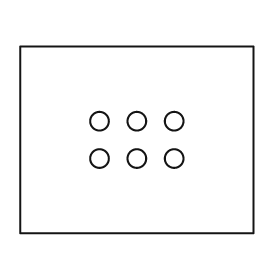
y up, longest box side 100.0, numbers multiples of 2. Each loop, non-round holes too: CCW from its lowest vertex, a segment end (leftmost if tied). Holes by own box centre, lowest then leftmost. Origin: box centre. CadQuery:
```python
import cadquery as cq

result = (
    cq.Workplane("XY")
    .moveTo(-50.0, -40.0)
    .lineTo(50.0, -40.0)
    .lineTo(50.0, 40.0)
    .lineTo(-50.0, 40.0)
    .close()
    .moveTo(-16.0, -8.0)
    .circle(4.0)
    .moveTo(0.0, -8.0)
    .circle(4.0)
    .moveTo(16.0, -8.0)
    .circle(4.0)
    .moveTo(-16.0, 8.0)
    .circle(4.0)
    .moveTo(0.0, 8.0)
    .circle(4.0)
    .moveTo(16.0, 8.0)
    .circle(4.0)
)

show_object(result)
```